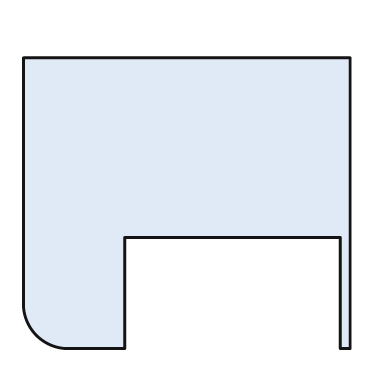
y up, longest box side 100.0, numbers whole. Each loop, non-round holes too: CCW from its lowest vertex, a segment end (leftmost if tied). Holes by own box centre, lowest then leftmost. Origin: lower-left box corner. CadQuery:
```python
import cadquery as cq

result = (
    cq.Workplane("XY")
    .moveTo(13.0, 0.0)
    .lineTo(31.0, 0.0)
    .lineTo(31.0, 34.0)
    .lineTo(97.0, 34.0)
    .lineTo(97.0, 0.0)
    .lineTo(100.0, 0.0)
    .lineTo(100.0, 89.0)
    .lineTo(0.0, 89.0)
    .lineTo(0.0, 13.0)
    .threePointArc((4.0, 4.0), (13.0, 0.0))
    .close()
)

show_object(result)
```